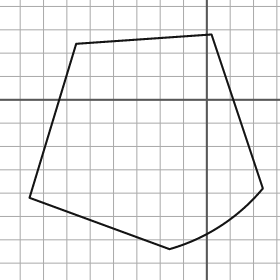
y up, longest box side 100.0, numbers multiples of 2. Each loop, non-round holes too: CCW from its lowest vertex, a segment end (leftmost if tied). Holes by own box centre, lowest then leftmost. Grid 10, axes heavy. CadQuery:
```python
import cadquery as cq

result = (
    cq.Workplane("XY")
    .moveTo(-16.0, -64.0)
    .threePointArc((6.0, -54.0), (24.0, -38.0))
    .lineTo(2.0, 28.0)
    .lineTo(-56.0, 24.0)
    .lineTo(-76.0, -42.0)
    .close()
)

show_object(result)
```